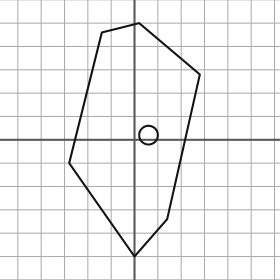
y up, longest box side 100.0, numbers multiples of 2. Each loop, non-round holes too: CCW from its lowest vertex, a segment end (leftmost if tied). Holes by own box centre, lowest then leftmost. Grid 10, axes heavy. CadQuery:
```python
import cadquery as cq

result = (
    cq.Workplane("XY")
    .moveTo(0.0, -50.0)
    .lineTo(14.0, -34.0)
    .lineTo(28.0, 28.0)
    .lineTo(2.0, 50.0)
    .lineTo(-14.0, 46.0)
    .lineTo(-28.0, -10.0)
    .close()
    .moveTo(6.0, 2.0)
    .circle(4.0)
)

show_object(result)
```